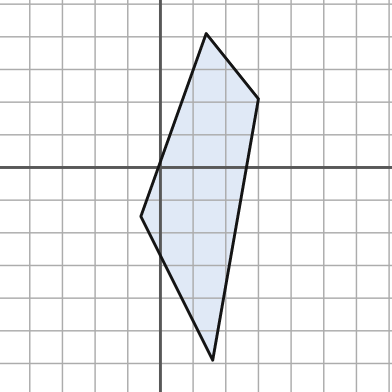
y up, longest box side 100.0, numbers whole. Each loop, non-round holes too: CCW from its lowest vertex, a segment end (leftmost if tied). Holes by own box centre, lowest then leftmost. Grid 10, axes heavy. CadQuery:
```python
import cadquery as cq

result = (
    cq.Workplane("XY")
    .moveTo(16.0, -59.0)
    .lineTo(30.0, 21.0)
    .lineTo(14.0, 41.0)
    .lineTo(-6.0, -15.0)
    .close()
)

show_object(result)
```